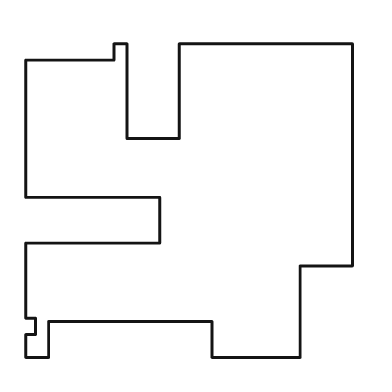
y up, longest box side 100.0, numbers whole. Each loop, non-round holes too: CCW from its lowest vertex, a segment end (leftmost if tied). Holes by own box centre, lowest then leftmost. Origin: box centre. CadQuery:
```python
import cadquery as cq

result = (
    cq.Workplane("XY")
    .moveTo(-50.0, -48.0)
    .lineTo(-43.0, -48.0)
    .lineTo(-43.0, -37.0)
    .lineTo(7.0, -37.0)
    .lineTo(7.0, -48.0)
    .lineTo(34.0, -48.0)
    .lineTo(34.0, -20.0)
    .lineTo(50.0, -20.0)
    .lineTo(50.0, 48.0)
    .lineTo(-3.0, 48.0)
    .lineTo(-3.0, 19.0)
    .lineTo(-19.0, 19.0)
    .lineTo(-19.0, 48.0)
    .lineTo(-23.0, 48.0)
    .lineTo(-23.0, 43.0)
    .lineTo(-50.0, 43.0)
    .lineTo(-50.0, 1.0)
    .lineTo(-9.0, 1.0)
    .lineTo(-9.0, -13.0)
    .lineTo(-50.0, -13.0)
    .lineTo(-50.0, -36.0)
    .lineTo(-47.0, -36.0)
    .lineTo(-47.0, -41.0)
    .lineTo(-50.0, -41.0)
    .close()
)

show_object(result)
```